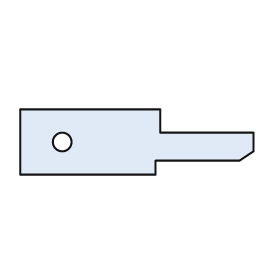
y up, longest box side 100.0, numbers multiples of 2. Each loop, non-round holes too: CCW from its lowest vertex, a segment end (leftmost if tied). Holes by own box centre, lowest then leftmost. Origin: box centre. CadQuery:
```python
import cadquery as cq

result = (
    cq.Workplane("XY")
    .moveTo(-50.0, -14.0)
    .lineTo(8.0, -14.0)
    .lineTo(8.0, -8.0)
    .lineTo(44.0, -8.0)
    .lineTo(50.0, -4.0)
    .lineTo(50.0, 4.0)
    .lineTo(10.0, 4.0)
    .lineTo(10.0, 14.0)
    .lineTo(-50.0, 14.0)
    .close()
    .moveTo(-32.0, 0.0)
    .circle(4.0)
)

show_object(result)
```